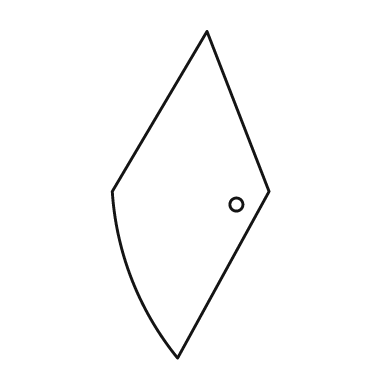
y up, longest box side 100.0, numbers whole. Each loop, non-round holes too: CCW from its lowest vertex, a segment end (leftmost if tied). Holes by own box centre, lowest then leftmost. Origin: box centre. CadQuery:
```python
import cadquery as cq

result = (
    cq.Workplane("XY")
    .moveTo(-4.0, -50.0)
    .lineTo(24.0, 1.0)
    .lineTo(5.0, 50.0)
    .lineTo(-24.0, 1.0)
    .threePointArc((-18.0, -26.0), (-4.0, -50.0))
    .close()
    .moveTo(14.0, -3.0)
    .circle(2.0)
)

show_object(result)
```